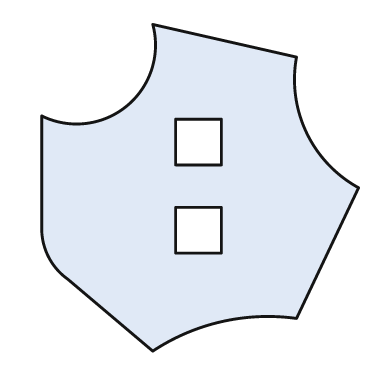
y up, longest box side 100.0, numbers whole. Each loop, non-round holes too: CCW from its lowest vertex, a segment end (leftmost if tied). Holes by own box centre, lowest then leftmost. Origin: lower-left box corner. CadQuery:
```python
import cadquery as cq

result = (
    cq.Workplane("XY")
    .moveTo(34.0, 0.0)
    .threePointArc((55.0, 9.0), (78.0, 10.0))
    .lineTo(97.0, 50.0)
    .threePointArc((81.0, 67.0), (78.0, 90.0))
    .lineTo(34.0, 100.0)
    .threePointArc((26.0, 75.0), (0.0, 72.0))
    .lineTo(0.0, 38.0)
    .threePointArc((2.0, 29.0), (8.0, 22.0))
    .close()
    .moveTo(41.0, 30.0)
    .lineTo(55.0, 30.0)
    .lineTo(55.0, 44.0)
    .lineTo(41.0, 44.0)
    .close()
    .moveTo(41.0, 57.0)
    .lineTo(55.0, 57.0)
    .lineTo(55.0, 71.0)
    .lineTo(41.0, 71.0)
    .close()
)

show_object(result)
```